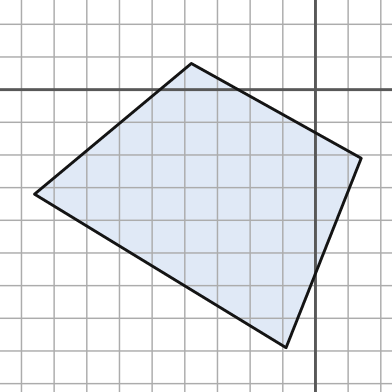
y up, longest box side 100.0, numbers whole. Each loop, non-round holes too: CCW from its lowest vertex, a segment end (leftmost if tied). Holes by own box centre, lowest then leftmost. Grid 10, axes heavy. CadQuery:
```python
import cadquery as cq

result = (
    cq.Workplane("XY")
    .moveTo(-9.0, -79.0)
    .lineTo(14.0, -21.0)
    .lineTo(-38.0, 8.0)
    .lineTo(-86.0, -32.0)
    .close()
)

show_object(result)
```